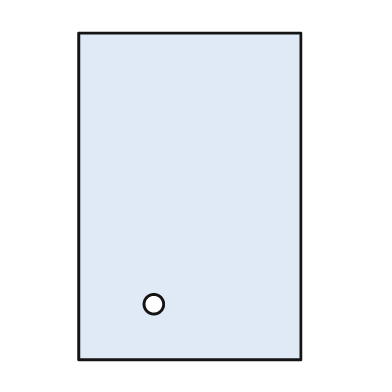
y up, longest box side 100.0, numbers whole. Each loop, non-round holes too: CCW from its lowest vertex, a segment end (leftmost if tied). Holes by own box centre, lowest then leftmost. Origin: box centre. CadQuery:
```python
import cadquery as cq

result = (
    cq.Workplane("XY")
    .moveTo(-34.0, -50.0)
    .lineTo(34.0, -50.0)
    .lineTo(34.0, 50.0)
    .lineTo(-34.0, 50.0)
    .close()
    .moveTo(-11.0, -33.0)
    .circle(3.0)
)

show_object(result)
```